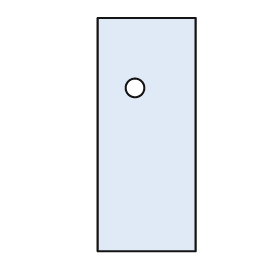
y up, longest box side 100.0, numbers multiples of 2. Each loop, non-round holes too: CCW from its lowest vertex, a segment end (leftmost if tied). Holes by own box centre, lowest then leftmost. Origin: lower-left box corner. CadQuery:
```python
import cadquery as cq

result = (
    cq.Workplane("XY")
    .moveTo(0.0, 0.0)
    .lineTo(42.0, 0.0)
    .lineTo(42.0, 100.0)
    .lineTo(0.0, 100.0)
    .close()
    .moveTo(16.0, 70.0)
    .circle(4.0)
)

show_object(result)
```